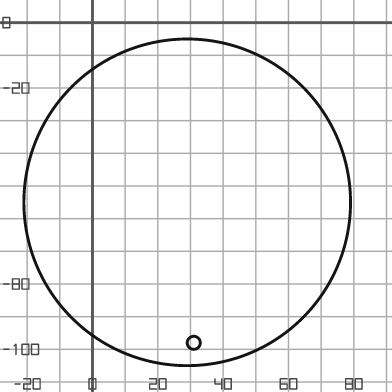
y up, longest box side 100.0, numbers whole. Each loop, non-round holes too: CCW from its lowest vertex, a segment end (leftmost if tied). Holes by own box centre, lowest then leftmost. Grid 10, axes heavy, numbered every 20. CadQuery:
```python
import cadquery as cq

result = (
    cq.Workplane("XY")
    .moveTo(29.0, -55.0)
    .circle(50.0)
    .moveTo(31.0, -98.0)
    .circle(2.0)
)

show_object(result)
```